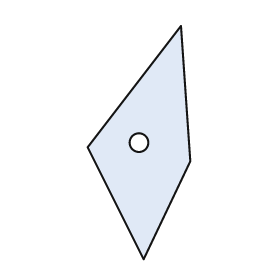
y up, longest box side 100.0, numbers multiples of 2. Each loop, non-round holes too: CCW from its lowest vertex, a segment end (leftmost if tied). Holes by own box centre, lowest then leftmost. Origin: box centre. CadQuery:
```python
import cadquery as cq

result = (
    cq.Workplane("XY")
    .moveTo(2.0, -50.0)
    .lineTo(22.0, -8.0)
    .lineTo(18.0, 50.0)
    .lineTo(-22.0, -2.0)
    .close()
    .moveTo(0.0, 0.0)
    .circle(4.0)
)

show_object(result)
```